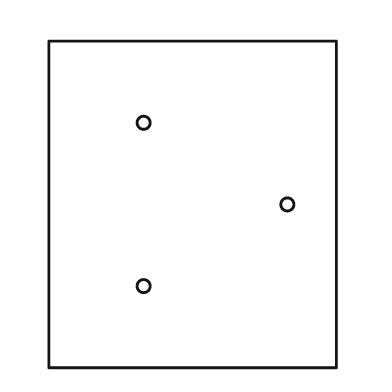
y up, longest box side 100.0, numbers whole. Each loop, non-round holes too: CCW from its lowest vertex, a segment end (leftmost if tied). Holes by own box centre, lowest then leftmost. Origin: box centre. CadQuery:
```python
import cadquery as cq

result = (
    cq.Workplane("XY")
    .moveTo(-44.0, -50.0)
    .lineTo(44.0, -50.0)
    .lineTo(44.0, 50.0)
    .lineTo(-44.0, 50.0)
    .close()
    .moveTo(-15.0, -25.0)
    .circle(2.0)
    .moveTo(29.0, 0.0)
    .circle(2.0)
    .moveTo(-15.0, 25.0)
    .circle(2.0)
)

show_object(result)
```